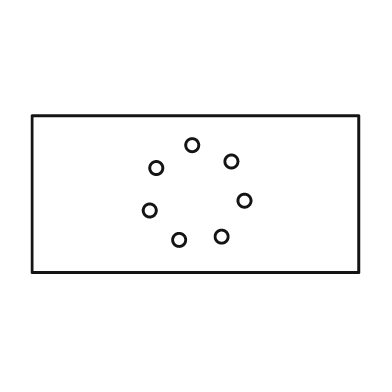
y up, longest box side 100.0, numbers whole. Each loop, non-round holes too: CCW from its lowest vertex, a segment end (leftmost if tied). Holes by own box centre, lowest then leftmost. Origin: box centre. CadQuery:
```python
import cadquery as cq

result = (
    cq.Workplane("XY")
    .moveTo(-50.0, -24.0)
    .lineTo(50.0, -24.0)
    .lineTo(50.0, 24.0)
    .lineTo(-50.0, 24.0)
    .close()
    .moveTo(-5.0, -14.0)
    .circle(2.0)
    .moveTo(8.0, -13.0)
    .circle(2.0)
    .moveTo(-14.0, -5.0)
    .circle(2.0)
    .moveTo(15.0, -2.0)
    .circle(2.0)
    .moveTo(-12.0, 8.0)
    .circle(2.0)
    .moveTo(11.0, 10.0)
    .circle(2.0)
    .moveTo(-1.0, 15.0)
    .circle(2.0)
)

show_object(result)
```